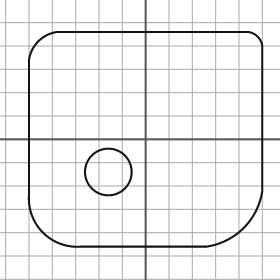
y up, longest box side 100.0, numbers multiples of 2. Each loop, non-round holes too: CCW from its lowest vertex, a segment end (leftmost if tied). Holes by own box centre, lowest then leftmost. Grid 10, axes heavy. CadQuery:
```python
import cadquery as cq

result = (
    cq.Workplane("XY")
    .moveTo(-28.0, -46.0)
    .lineTo(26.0, -46.0)
    .threePointArc((42.0, -38.0), (50.0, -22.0))
    .lineTo(50.0, 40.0)
    .threePointArc((48.0, 44.0), (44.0, 46.0))
    .lineTo(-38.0, 46.0)
    .threePointArc((-46.0, 42.0), (-50.0, 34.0))
    .lineTo(-50.0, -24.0)
    .threePointArc((-44.0, -40.0), (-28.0, -46.0))
    .close()
    .moveTo(-16.0, -14.0)
    .circle(10.0)
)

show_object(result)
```